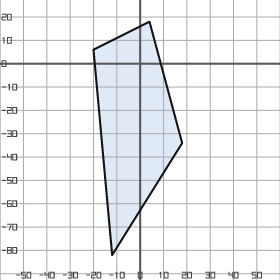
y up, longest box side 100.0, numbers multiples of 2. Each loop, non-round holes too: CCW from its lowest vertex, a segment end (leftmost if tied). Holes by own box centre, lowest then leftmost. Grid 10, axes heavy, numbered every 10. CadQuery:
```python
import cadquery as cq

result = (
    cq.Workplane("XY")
    .moveTo(-12.0, -82.0)
    .lineTo(18.0, -34.0)
    .lineTo(4.0, 18.0)
    .lineTo(-20.0, 6.0)
    .close()
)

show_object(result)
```